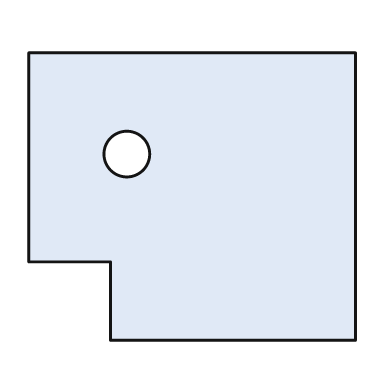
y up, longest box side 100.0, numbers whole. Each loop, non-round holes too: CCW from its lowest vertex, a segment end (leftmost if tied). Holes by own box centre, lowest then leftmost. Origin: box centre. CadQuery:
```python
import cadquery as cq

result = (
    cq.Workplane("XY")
    .moveTo(-25.0, -44.0)
    .lineTo(50.0, -44.0)
    .lineTo(50.0, 44.0)
    .lineTo(-50.0, 44.0)
    .lineTo(-50.0, -20.0)
    .lineTo(-25.0, -20.0)
    .close()
    .moveTo(-20.0, 13.0)
    .circle(7.0)
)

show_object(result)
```